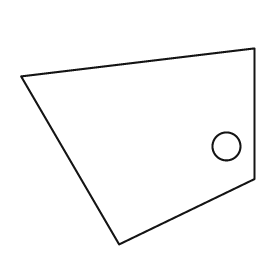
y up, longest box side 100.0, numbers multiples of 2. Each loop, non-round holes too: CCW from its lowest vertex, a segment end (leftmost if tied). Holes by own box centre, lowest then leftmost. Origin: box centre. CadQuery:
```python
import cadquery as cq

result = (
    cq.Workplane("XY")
    .moveTo(-8.0, -42.0)
    .lineTo(50.0, -14.0)
    .lineTo(50.0, 42.0)
    .lineTo(-50.0, 30.0)
    .close()
    .moveTo(38.0, 0.0)
    .circle(6.0)
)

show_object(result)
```